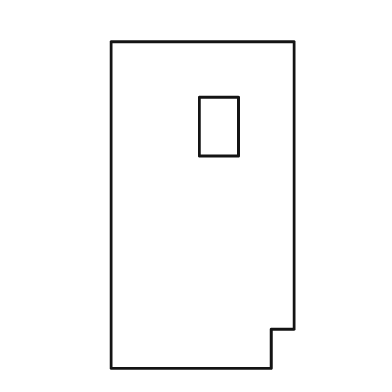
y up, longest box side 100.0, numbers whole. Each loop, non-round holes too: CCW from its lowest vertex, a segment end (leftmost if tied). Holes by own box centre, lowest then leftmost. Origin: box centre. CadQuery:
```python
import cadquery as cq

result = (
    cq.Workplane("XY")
    .moveTo(-28.0, -50.0)
    .lineTo(21.0, -50.0)
    .lineTo(21.0, -38.0)
    .lineTo(28.0, -38.0)
    .lineTo(28.0, 50.0)
    .lineTo(-28.0, 50.0)
    .close()
    .moveTo(-1.0, 15.0)
    .lineTo(11.0, 15.0)
    .lineTo(11.0, 33.0)
    .lineTo(-1.0, 33.0)
    .close()
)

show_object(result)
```